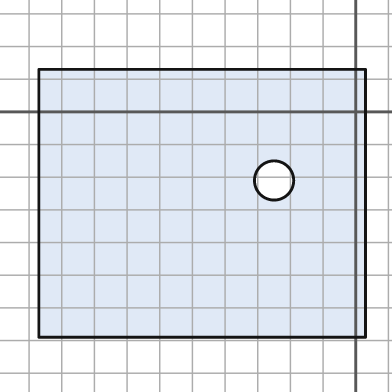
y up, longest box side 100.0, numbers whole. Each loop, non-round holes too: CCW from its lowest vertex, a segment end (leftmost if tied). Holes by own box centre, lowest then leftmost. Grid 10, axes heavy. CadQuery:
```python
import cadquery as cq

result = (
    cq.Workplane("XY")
    .moveTo(-97.0, -69.0)
    .lineTo(3.0, -69.0)
    .lineTo(3.0, 13.0)
    .lineTo(-97.0, 13.0)
    .close()
    .moveTo(-25.0, -21.0)
    .circle(6.0)
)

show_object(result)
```